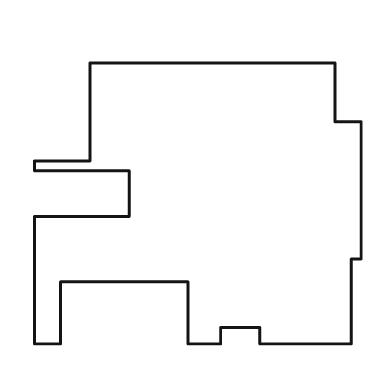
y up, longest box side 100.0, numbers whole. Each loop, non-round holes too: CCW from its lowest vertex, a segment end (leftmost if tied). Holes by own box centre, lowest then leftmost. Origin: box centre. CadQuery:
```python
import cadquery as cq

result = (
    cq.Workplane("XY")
    .moveTo(-50.0, -43.0)
    .lineTo(-42.0, -43.0)
    .lineTo(-42.0, -24.0)
    .lineTo(-3.0, -24.0)
    .lineTo(-3.0, -43.0)
    .lineTo(7.0, -43.0)
    .lineTo(7.0, -38.0)
    .lineTo(19.0, -38.0)
    .lineTo(19.0, -43.0)
    .lineTo(47.0, -43.0)
    .lineTo(47.0, -17.0)
    .lineTo(50.0, -17.0)
    .lineTo(50.0, 25.0)
    .lineTo(42.0, 25.0)
    .lineTo(42.0, 43.0)
    .lineTo(-33.0, 43.0)
    .lineTo(-33.0, 13.0)
    .lineTo(-50.0, 13.0)
    .lineTo(-50.0, 10.0)
    .lineTo(-21.0, 10.0)
    .lineTo(-21.0, -4.0)
    .lineTo(-50.0, -4.0)
    .close()
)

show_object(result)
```